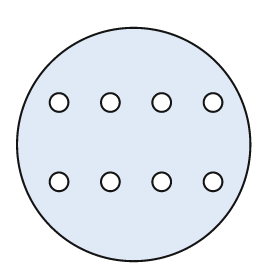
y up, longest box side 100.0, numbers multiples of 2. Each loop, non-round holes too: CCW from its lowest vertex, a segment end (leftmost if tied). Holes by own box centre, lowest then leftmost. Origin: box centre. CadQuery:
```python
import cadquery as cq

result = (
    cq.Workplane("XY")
    .moveTo(0.0, 0.0)
    .circle(50.0)
    .moveTo(-32.0, -16.0)
    .circle(4.0)
    .moveTo(-10.0, -16.0)
    .circle(4.0)
    .moveTo(12.0, -16.0)
    .circle(4.0)
    .moveTo(34.0, -16.0)
    .circle(4.0)
    .moveTo(-32.0, 18.0)
    .circle(4.0)
    .moveTo(-10.0, 18.0)
    .circle(4.0)
    .moveTo(12.0, 18.0)
    .circle(4.0)
    .moveTo(34.0, 18.0)
    .circle(4.0)
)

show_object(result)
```